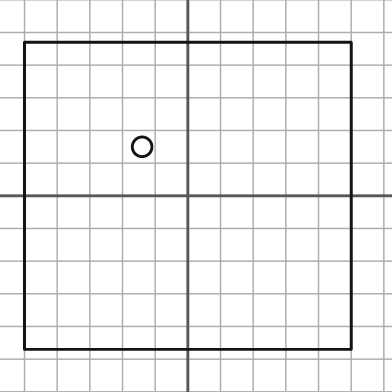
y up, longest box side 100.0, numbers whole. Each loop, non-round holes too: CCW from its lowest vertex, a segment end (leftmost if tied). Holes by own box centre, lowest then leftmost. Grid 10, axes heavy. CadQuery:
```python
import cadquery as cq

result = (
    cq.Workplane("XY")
    .moveTo(-50.0, -47.0)
    .lineTo(50.0, -47.0)
    .lineTo(50.0, 47.0)
    .lineTo(-50.0, 47.0)
    .close()
    .moveTo(-14.0, 15.0)
    .circle(3.0)
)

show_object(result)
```